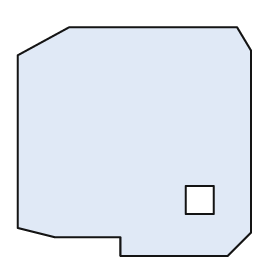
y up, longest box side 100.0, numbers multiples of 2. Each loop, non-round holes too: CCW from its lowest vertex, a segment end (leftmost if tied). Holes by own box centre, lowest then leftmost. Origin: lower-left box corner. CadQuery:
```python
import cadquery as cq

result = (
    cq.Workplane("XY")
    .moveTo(44.0, 0.0)
    .lineTo(90.0, 0.0)
    .lineTo(100.0, 10.0)
    .lineTo(100.0, 88.0)
    .lineTo(94.0, 98.0)
    .lineTo(22.0, 98.0)
    .lineTo(0.0, 86.0)
    .lineTo(0.0, 12.0)
    .lineTo(16.0, 8.0)
    .lineTo(44.0, 8.0)
    .close()
    .moveTo(72.0, 18.0)
    .lineTo(84.0, 18.0)
    .lineTo(84.0, 30.0)
    .lineTo(72.0, 30.0)
    .close()
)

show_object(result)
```